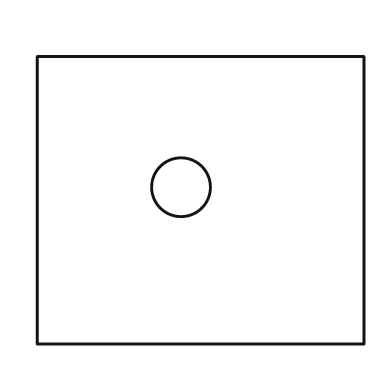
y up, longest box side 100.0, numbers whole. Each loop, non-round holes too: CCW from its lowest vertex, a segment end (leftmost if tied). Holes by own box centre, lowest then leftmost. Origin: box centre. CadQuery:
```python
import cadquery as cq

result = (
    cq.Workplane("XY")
    .moveTo(-50.0, -44.0)
    .lineTo(50.0, -44.0)
    .lineTo(50.0, 44.0)
    .lineTo(-50.0, 44.0)
    .close()
    .moveTo(-6.0, 4.0)
    .circle(9.0)
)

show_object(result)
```